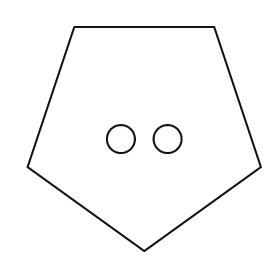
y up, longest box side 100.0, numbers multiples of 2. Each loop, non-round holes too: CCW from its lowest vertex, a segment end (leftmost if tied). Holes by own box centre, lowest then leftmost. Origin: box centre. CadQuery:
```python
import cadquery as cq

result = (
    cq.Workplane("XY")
    .moveTo(0.0, -48.0)
    .lineTo(50.0, -12.0)
    .lineTo(30.0, 48.0)
    .lineTo(-30.0, 48.0)
    .lineTo(-50.0, -12.0)
    .close()
    .moveTo(-10.0, 0.0)
    .circle(6.0)
    .moveTo(10.0, 0.0)
    .circle(6.0)
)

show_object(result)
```